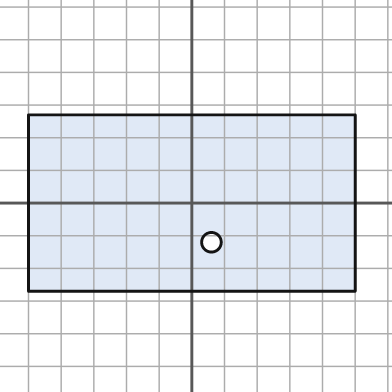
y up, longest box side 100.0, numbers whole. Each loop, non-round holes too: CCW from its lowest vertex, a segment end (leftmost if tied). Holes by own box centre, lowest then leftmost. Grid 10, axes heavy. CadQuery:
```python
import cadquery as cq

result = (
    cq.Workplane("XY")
    .moveTo(-50.0, -27.0)
    .lineTo(50.0, -27.0)
    .lineTo(50.0, 27.0)
    .lineTo(-50.0, 27.0)
    .close()
    .moveTo(6.0, -12.0)
    .circle(3.0)
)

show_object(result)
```